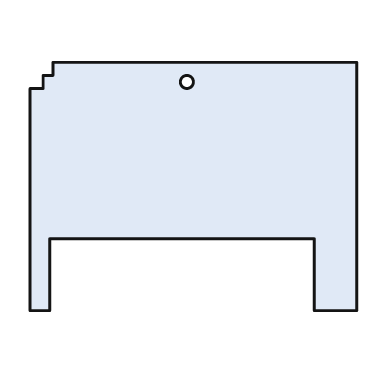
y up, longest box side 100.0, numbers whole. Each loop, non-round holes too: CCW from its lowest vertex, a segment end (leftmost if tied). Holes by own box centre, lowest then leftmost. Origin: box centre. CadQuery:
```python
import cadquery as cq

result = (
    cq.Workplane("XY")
    .moveTo(-50.0, -38.0)
    .lineTo(-44.0, -38.0)
    .lineTo(-44.0, -16.0)
    .lineTo(37.0, -16.0)
    .lineTo(37.0, -38.0)
    .lineTo(50.0, -38.0)
    .lineTo(50.0, 38.0)
    .lineTo(-43.0, 38.0)
    .lineTo(-43.0, 34.0)
    .lineTo(-46.0, 34.0)
    .lineTo(-46.0, 30.0)
    .lineTo(-50.0, 30.0)
    .close()
    .moveTo(-2.0, 32.0)
    .circle(2.0)
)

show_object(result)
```